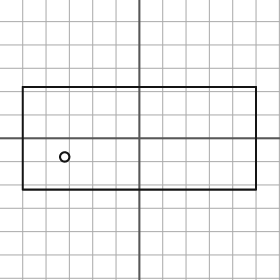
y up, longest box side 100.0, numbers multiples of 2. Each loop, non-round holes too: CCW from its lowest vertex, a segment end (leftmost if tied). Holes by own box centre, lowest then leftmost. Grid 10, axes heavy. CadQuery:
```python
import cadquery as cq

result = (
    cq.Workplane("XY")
    .moveTo(-50.0, -22.0)
    .lineTo(50.0, -22.0)
    .lineTo(50.0, 22.0)
    .lineTo(-50.0, 22.0)
    .close()
    .moveTo(-32.0, -8.0)
    .circle(2.0)
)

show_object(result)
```